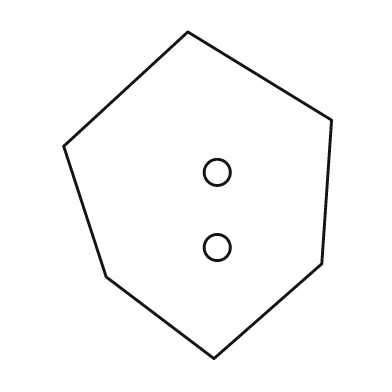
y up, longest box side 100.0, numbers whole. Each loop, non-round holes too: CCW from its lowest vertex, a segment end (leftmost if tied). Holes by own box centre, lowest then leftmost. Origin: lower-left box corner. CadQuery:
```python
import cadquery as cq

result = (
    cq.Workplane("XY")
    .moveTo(46.0, 0.0)
    .lineTo(79.0, 29.0)
    .lineTo(82.0, 73.0)
    .lineTo(38.0, 100.0)
    .lineTo(0.0, 65.0)
    .lineTo(13.0, 25.0)
    .close()
    .moveTo(47.0, 34.0)
    .circle(4.0)
    .moveTo(47.0, 57.0)
    .circle(4.0)
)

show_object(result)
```